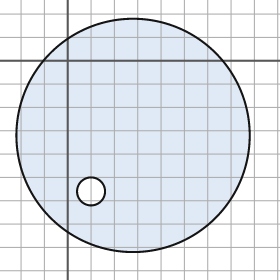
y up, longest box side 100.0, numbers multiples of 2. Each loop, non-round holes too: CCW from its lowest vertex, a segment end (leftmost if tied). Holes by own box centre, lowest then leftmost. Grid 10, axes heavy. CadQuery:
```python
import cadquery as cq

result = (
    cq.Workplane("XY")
    .moveTo(28.0, -32.0)
    .circle(50.0)
    .moveTo(10.0, -56.0)
    .circle(6.0)
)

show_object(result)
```